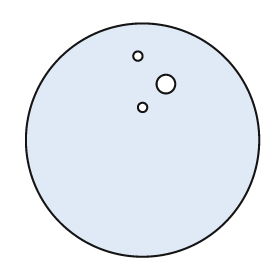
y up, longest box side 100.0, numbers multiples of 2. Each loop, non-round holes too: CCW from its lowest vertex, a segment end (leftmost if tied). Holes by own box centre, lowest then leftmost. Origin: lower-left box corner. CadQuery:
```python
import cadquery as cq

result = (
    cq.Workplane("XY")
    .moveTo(50.0, 50.0)
    .circle(50.0)
    .moveTo(50.0, 64.0)
    .circle(2.0)
    .moveTo(60.0, 74.0)
    .circle(4.0)
    .moveTo(48.0, 86.0)
    .circle(2.0)
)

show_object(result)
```